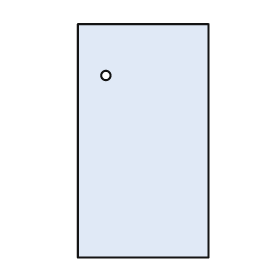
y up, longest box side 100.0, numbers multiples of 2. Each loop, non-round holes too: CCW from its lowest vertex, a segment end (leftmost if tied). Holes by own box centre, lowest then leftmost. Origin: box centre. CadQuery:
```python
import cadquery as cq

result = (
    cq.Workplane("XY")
    .moveTo(-28.0, -50.0)
    .lineTo(28.0, -50.0)
    .lineTo(28.0, 50.0)
    .lineTo(-28.0, 50.0)
    .close()
    .moveTo(-16.0, 28.0)
    .circle(2.0)
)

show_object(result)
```